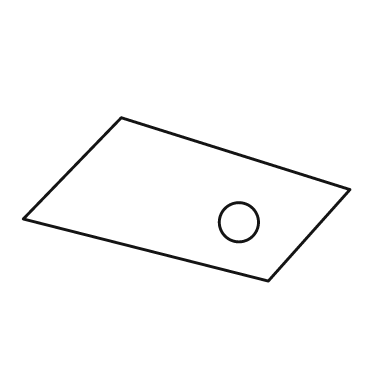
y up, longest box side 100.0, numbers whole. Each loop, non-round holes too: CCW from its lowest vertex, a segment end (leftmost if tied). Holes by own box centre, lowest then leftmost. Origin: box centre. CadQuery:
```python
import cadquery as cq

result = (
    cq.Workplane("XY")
    .moveTo(25.0, -25.0)
    .lineTo(50.0, 3.0)
    .lineTo(-20.0, 25.0)
    .lineTo(-50.0, -6.0)
    .close()
    .moveTo(16.0, -7.0)
    .circle(6.0)
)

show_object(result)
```